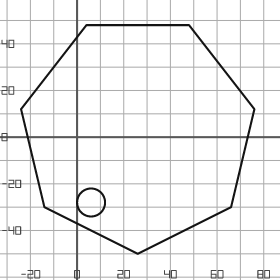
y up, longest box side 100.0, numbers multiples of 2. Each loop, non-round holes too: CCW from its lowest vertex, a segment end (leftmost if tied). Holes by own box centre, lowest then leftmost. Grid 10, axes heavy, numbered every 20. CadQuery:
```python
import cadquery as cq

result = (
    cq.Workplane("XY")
    .moveTo(26.0, -50.0)
    .lineTo(66.0, -30.0)
    .lineTo(76.0, 12.0)
    .lineTo(48.0, 48.0)
    .lineTo(4.0, 48.0)
    .lineTo(-24.0, 12.0)
    .lineTo(-14.0, -30.0)
    .close()
    .moveTo(6.0, -28.0)
    .circle(6.0)
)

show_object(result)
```